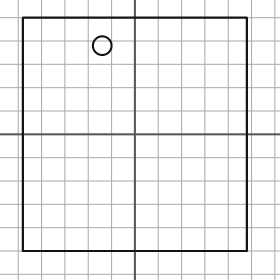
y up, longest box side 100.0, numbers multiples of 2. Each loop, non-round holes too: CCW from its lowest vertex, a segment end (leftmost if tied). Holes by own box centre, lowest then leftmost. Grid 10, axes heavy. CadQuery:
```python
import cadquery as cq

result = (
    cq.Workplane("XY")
    .moveTo(-48.0, -50.0)
    .lineTo(48.0, -50.0)
    .lineTo(48.0, 50.0)
    .lineTo(-48.0, 50.0)
    .close()
    .moveTo(-14.0, 38.0)
    .circle(4.0)
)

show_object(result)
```